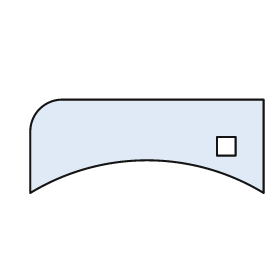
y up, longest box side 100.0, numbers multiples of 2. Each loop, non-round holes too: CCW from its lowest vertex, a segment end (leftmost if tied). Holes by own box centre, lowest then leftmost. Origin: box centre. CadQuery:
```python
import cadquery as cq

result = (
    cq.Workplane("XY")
    .moveTo(-50.0, -20.0)
    .threePointArc((0.0, -6.0), (50.0, -20.0))
    .lineTo(50.0, 20.0)
    .lineTo(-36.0, 20.0)
    .threePointArc((-46.0, 16.0), (-50.0, 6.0))
    .close()
    .moveTo(30.0, -4.0)
    .lineTo(38.0, -4.0)
    .lineTo(38.0, 4.0)
    .lineTo(30.0, 4.0)
    .close()
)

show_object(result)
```